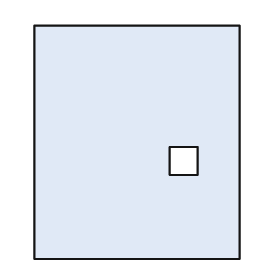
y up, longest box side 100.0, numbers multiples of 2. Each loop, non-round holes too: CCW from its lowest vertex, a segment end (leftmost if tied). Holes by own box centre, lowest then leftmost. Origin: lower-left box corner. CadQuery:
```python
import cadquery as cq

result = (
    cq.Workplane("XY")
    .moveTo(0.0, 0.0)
    .lineTo(88.0, 0.0)
    .lineTo(88.0, 100.0)
    .lineTo(0.0, 100.0)
    .close()
    .moveTo(58.0, 36.0)
    .lineTo(70.0, 36.0)
    .lineTo(70.0, 48.0)
    .lineTo(58.0, 48.0)
    .close()
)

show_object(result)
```